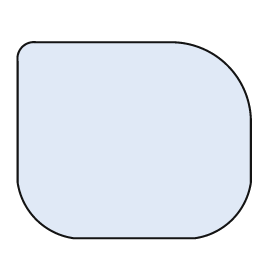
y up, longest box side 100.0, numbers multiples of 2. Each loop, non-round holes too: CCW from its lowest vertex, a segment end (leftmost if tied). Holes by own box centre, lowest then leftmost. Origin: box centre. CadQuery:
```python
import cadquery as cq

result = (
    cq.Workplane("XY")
    .moveTo(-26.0, -42.0)
    .lineTo(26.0, -42.0)
    .threePointArc((42.0, -34.0), (50.0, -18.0))
    .lineTo(50.0, 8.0)
    .threePointArc((40.0, 32.0), (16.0, 42.0))
    .lineTo(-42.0, 42.0)
    .threePointArc((-48.0, 40.0), (-50.0, 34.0))
    .lineTo(-50.0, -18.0)
    .threePointArc((-42.0, -34.0), (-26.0, -42.0))
    .close()
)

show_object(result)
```